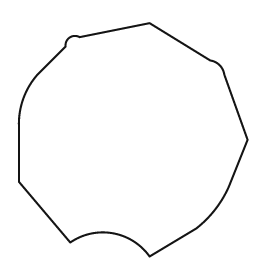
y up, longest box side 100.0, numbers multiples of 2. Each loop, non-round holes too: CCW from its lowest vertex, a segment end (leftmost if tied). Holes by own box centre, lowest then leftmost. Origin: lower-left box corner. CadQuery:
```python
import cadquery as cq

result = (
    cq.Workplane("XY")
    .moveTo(56.0, 0.0)
    .lineTo(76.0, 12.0)
    .threePointArc((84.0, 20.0), (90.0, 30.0))
    .lineTo(98.0, 50.0)
    .lineTo(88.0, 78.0)
    .threePointArc((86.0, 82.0), (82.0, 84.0))
    .lineTo(56.0, 100.0)
    .lineTo(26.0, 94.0)
    .threePointArc((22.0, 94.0), (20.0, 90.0))
    .lineTo(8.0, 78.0)
    .threePointArc((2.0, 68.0), (0.0, 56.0))
    .lineTo(0.0, 32.0)
    .lineTo(22.0, 6.0)
    .threePointArc((40.0, 10.0), (56.0, 0.0))
    .close()
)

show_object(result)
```